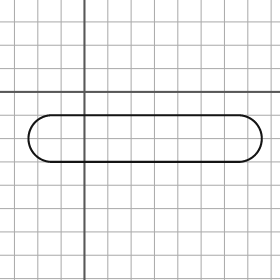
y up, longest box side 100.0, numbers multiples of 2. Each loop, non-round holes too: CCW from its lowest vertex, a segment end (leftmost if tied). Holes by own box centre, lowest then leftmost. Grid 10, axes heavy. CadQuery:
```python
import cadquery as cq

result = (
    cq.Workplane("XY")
    .moveTo(-14.0, -30.0)
    .lineTo(66.0, -30.0)
    .threePointArc((76.0, -20.0), (66.0, -10.0))
    .lineTo(-14.0, -10.0)
    .threePointArc((-24.0, -20.0), (-14.0, -30.0))
    .close()
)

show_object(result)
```